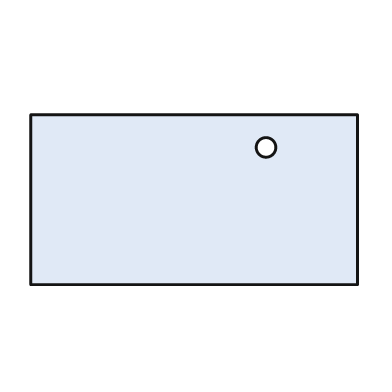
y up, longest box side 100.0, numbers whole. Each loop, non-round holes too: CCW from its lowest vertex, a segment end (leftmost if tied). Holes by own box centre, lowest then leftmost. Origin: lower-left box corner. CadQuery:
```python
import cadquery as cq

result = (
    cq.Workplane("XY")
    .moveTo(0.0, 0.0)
    .lineTo(100.0, 0.0)
    .lineTo(100.0, 52.0)
    .lineTo(0.0, 52.0)
    .close()
    .moveTo(72.0, 42.0)
    .circle(3.0)
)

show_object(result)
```